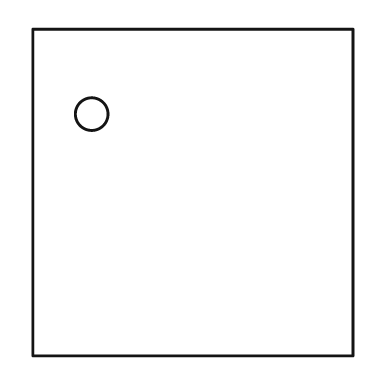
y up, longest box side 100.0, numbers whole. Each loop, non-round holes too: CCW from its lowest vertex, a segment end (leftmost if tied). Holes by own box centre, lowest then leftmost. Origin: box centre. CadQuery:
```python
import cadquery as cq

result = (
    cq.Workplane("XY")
    .moveTo(-49.0, -50.0)
    .lineTo(49.0, -50.0)
    .lineTo(49.0, 50.0)
    .lineTo(-49.0, 50.0)
    .close()
    .moveTo(-31.0, 24.0)
    .circle(5.0)
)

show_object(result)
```